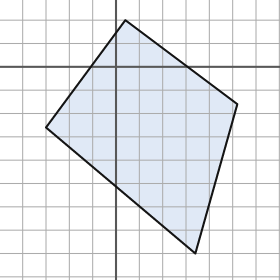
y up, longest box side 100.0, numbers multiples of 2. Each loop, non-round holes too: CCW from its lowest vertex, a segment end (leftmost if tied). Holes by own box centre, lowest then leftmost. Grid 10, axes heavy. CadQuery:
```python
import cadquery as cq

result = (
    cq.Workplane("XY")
    .moveTo(34.0, -80.0)
    .lineTo(52.0, -16.0)
    .lineTo(4.0, 20.0)
    .lineTo(-30.0, -26.0)
    .close()
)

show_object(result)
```